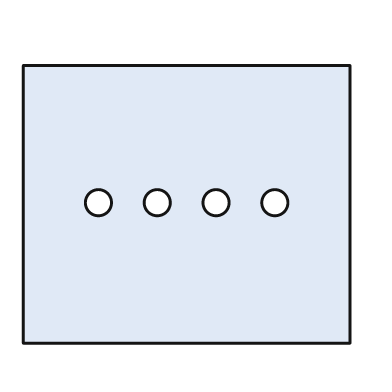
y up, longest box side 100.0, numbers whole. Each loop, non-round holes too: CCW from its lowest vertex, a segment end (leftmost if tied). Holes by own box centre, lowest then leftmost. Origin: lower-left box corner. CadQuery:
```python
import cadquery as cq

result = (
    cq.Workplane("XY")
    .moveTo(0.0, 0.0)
    .lineTo(100.0, 0.0)
    .lineTo(100.0, 85.0)
    .lineTo(0.0, 85.0)
    .close()
    .moveTo(23.0, 43.0)
    .circle(4.0)
    .moveTo(41.0, 43.0)
    .circle(4.0)
    .moveTo(59.0, 43.0)
    .circle(4.0)
    .moveTo(77.0, 43.0)
    .circle(4.0)
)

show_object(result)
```